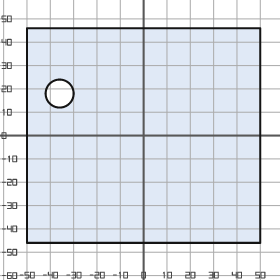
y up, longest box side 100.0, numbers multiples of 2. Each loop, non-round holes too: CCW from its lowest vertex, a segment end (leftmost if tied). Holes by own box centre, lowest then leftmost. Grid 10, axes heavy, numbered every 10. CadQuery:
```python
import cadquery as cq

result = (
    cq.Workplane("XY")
    .moveTo(-50.0, -46.0)
    .lineTo(50.0, -46.0)
    .lineTo(50.0, 46.0)
    .lineTo(-50.0, 46.0)
    .close()
    .moveTo(-36.0, 18.0)
    .circle(6.0)
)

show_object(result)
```